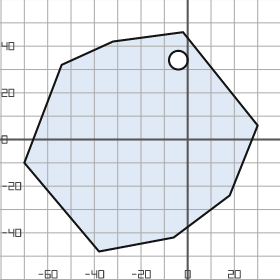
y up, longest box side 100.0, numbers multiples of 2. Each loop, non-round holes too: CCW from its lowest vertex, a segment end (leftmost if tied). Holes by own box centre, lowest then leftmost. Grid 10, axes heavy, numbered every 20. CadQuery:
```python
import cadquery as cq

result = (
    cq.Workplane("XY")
    .moveTo(-38.0, -48.0)
    .lineTo(-6.0, -42.0)
    .lineTo(18.0, -24.0)
    .lineTo(30.0, 6.0)
    .lineTo(-2.0, 46.0)
    .lineTo(-32.0, 42.0)
    .lineTo(-54.0, 32.0)
    .lineTo(-70.0, -10.0)
    .close()
    .moveTo(-4.0, 34.0)
    .circle(4.0)
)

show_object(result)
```